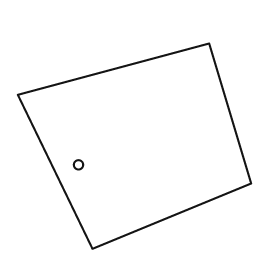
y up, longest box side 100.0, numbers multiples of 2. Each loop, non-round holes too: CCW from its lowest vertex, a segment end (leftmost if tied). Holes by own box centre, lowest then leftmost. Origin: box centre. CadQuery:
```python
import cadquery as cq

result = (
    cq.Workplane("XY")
    .moveTo(-18.0, -44.0)
    .lineTo(50.0, -16.0)
    .lineTo(32.0, 44.0)
    .lineTo(-50.0, 22.0)
    .close()
    .moveTo(-24.0, -8.0)
    .circle(2.0)
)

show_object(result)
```